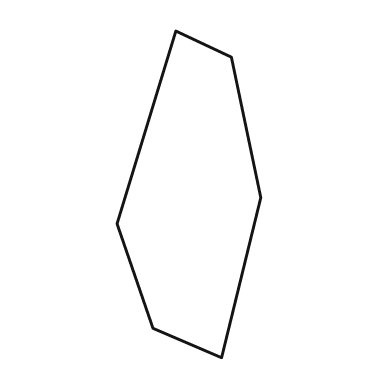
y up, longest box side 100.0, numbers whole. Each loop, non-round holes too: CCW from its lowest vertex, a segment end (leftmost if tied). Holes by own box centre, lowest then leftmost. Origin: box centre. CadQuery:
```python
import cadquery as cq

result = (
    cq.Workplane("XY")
    .moveTo(10.0, -50.0)
    .lineTo(22.0, -1.0)
    .lineTo(13.0, 42.0)
    .lineTo(-4.0, 50.0)
    .lineTo(-22.0, -9.0)
    .lineTo(-11.0, -41.0)
    .close()
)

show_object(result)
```